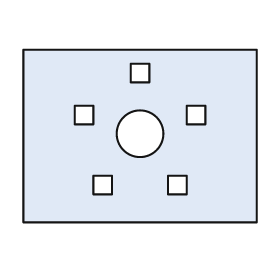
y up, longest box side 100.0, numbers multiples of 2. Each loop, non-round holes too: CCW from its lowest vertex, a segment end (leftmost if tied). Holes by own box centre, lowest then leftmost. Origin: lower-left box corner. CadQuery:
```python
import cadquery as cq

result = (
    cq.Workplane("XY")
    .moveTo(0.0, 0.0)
    .lineTo(100.0, 0.0)
    .lineTo(100.0, 74.0)
    .lineTo(0.0, 74.0)
    .close()
    .moveTo(30.0, 12.0)
    .lineTo(38.0, 12.0)
    .lineTo(38.0, 20.0)
    .lineTo(30.0, 20.0)
    .close()
    .moveTo(62.0, 12.0)
    .lineTo(70.0, 12.0)
    .lineTo(70.0, 20.0)
    .lineTo(62.0, 20.0)
    .close()
    .moveTo(50.0, 38.0)
    .circle(10.0)
    .moveTo(22.0, 42.0)
    .lineTo(30.0, 42.0)
    .lineTo(30.0, 50.0)
    .lineTo(22.0, 50.0)
    .close()
    .moveTo(70.0, 42.0)
    .lineTo(78.0, 42.0)
    .lineTo(78.0, 50.0)
    .lineTo(70.0, 50.0)
    .close()
    .moveTo(46.0, 60.0)
    .lineTo(54.0, 60.0)
    .lineTo(54.0, 68.0)
    .lineTo(46.0, 68.0)
    .close()
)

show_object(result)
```